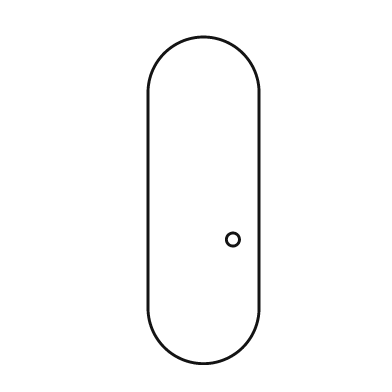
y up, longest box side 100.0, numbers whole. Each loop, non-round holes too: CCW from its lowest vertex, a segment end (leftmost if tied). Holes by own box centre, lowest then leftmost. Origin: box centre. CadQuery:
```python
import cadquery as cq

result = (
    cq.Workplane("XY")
    .moveTo(-17.0, -33.0)
    .threePointArc((0.0, -50.0), (17.0, -33.0))
    .lineTo(17.0, 33.0)
    .threePointArc((0.0, 50.0), (-17.0, 33.0))
    .close()
    .moveTo(9.0, -12.0)
    .circle(2.0)
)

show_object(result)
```